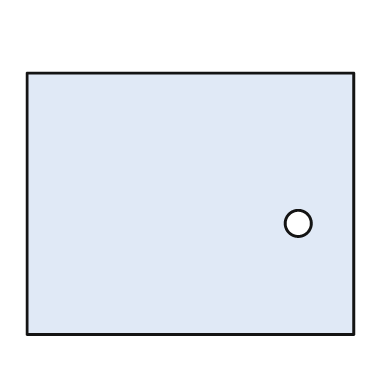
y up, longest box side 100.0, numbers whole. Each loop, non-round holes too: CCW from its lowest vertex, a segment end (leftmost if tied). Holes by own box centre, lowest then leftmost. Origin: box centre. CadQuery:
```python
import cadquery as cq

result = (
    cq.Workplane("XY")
    .moveTo(-50.0, -40.0)
    .lineTo(50.0, -40.0)
    .lineTo(50.0, 40.0)
    .lineTo(-50.0, 40.0)
    .close()
    .moveTo(33.0, -6.0)
    .circle(4.0)
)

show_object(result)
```